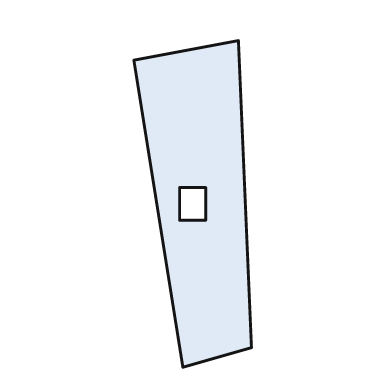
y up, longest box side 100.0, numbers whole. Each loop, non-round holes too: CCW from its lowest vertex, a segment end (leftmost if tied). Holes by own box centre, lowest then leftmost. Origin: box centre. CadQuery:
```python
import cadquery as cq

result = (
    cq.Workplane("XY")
    .moveTo(-3.0, -50.0)
    .lineTo(18.0, -44.0)
    .lineTo(14.0, 50.0)
    .lineTo(-18.0, 44.0)
    .close()
    .moveTo(-4.0, -5.0)
    .lineTo(4.0, -5.0)
    .lineTo(4.0, 5.0)
    .lineTo(-4.0, 5.0)
    .close()
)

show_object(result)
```